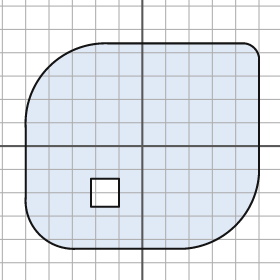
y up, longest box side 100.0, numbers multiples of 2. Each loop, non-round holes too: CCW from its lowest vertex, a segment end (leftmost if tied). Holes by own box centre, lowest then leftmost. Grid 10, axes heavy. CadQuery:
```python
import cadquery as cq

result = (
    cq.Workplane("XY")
    .moveTo(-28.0, -44.0)
    .lineTo(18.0, -44.0)
    .threePointArc((40.0, -34.0), (50.0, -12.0))
    .lineTo(50.0, 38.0)
    .threePointArc((48.0, 42.0), (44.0, 44.0))
    .lineTo(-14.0, 44.0)
    .threePointArc((-40.0, 34.0), (-50.0, 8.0))
    .lineTo(-50.0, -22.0)
    .threePointArc((-44.0, -38.0), (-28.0, -44.0))
    .close()
    .moveTo(-22.0, -26.0)
    .lineTo(-10.0, -26.0)
    .lineTo(-10.0, -14.0)
    .lineTo(-22.0, -14.0)
    .close()
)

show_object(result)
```